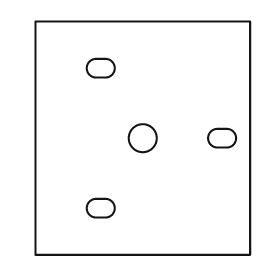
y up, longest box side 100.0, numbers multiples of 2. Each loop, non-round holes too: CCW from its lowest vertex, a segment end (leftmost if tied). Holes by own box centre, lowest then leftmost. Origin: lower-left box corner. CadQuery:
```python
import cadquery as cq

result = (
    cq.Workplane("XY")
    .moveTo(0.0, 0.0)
    .lineTo(92.0, 0.0)
    .lineTo(92.0, 100.0)
    .lineTo(0.0, 100.0)
    .close()
    .moveTo(26.0, 16.0)
    .lineTo(30.0, 16.0)
    .threePointArc((34.0, 20.0), (30.0, 24.0))
    .lineTo(26.0, 24.0)
    .threePointArc((22.0, 20.0), (26.0, 16.0))
    .close()
    .moveTo(46.0, 50.0)
    .circle(6.0)
    .moveTo(78.0, 46.0)
    .lineTo(82.0, 46.0)
    .threePointArc((86.0, 50.0), (82.0, 54.0))
    .lineTo(78.0, 54.0)
    .threePointArc((74.0, 50.0), (78.0, 46.0))
    .close()
    .moveTo(26.0, 76.0)
    .lineTo(30.0, 76.0)
    .threePointArc((34.0, 80.0), (30.0, 84.0))
    .lineTo(26.0, 84.0)
    .threePointArc((22.0, 80.0), (26.0, 76.0))
    .close()
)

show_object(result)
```